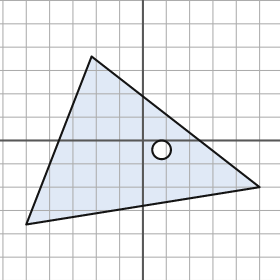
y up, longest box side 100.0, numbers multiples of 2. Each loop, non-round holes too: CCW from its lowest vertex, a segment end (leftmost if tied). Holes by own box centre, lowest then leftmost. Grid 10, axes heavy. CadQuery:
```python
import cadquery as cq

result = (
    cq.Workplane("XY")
    .moveTo(-50.0, -36.0)
    .lineTo(50.0, -20.0)
    .lineTo(-22.0, 36.0)
    .close()
    .moveTo(8.0, -4.0)
    .circle(4.0)
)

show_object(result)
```